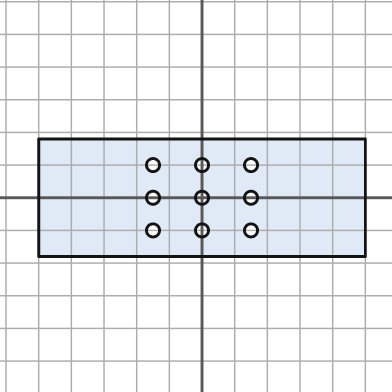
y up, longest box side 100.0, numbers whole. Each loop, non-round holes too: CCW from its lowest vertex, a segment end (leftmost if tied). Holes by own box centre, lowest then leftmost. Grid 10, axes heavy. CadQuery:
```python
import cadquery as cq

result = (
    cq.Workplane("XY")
    .moveTo(-50.0, -18.0)
    .lineTo(50.0, -18.0)
    .lineTo(50.0, 18.0)
    .lineTo(-50.0, 18.0)
    .close()
    .moveTo(-15.0, -10.0)
    .circle(2.0)
    .moveTo(0.0, -10.0)
    .circle(2.0)
    .moveTo(15.0, -10.0)
    .circle(2.0)
    .moveTo(-15.0, 0.0)
    .circle(2.0)
    .moveTo(0.0, 0.0)
    .circle(2.0)
    .moveTo(15.0, 0.0)
    .circle(2.0)
    .moveTo(-15.0, 10.0)
    .circle(2.0)
    .moveTo(0.0, 10.0)
    .circle(2.0)
    .moveTo(15.0, 10.0)
    .circle(2.0)
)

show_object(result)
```